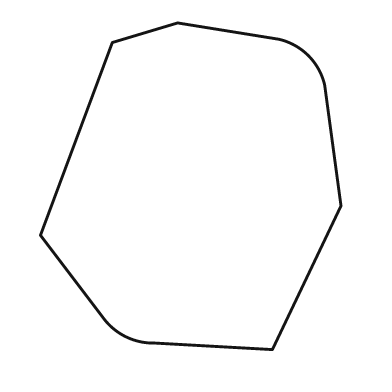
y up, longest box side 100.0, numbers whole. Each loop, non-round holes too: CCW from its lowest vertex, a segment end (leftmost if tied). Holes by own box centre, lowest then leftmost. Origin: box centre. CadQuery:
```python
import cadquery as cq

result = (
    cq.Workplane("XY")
    .moveTo(25.0, -50.0)
    .lineTo(46.0, -6.0)
    .lineTo(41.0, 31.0)
    .threePointArc((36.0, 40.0), (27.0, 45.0))
    .lineTo(-4.0, 50.0)
    .lineTo(-24.0, 44.0)
    .lineTo(-46.0, -15.0)
    .lineTo(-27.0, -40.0)
    .threePointArc((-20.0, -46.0), (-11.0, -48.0))
    .close()
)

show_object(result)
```